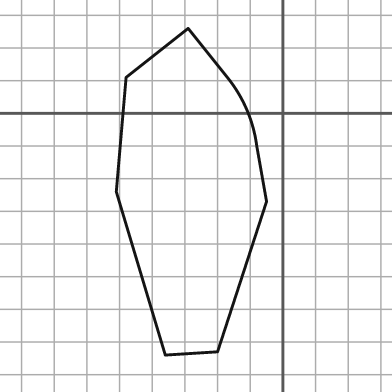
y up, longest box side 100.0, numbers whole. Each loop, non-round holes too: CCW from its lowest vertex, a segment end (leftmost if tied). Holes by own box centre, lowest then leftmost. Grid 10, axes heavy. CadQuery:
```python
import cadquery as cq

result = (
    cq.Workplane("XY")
    .moveTo(-36.0, -74.0)
    .lineTo(-20.0, -73.0)
    .lineTo(-5.0, -27.0)
    .lineTo(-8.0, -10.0)
    .threePointArc((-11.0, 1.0), (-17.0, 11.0))
    .lineTo(-29.0, 26.0)
    .lineTo(-48.0, 11.0)
    .lineTo(-51.0, -24.0)
    .close()
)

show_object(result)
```